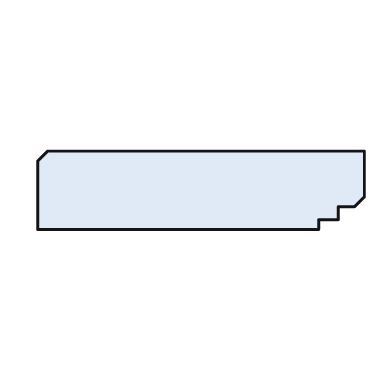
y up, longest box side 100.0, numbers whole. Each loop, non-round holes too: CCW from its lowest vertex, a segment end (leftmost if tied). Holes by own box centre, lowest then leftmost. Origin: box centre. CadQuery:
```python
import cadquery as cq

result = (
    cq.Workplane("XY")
    .moveTo(-50.0, -12.0)
    .lineTo(36.0, -12.0)
    .lineTo(36.0, -9.0)
    .lineTo(42.0, -9.0)
    .lineTo(42.0, -5.0)
    .lineTo(47.0, -5.0)
    .lineTo(50.0, -2.0)
    .lineTo(50.0, 12.0)
    .lineTo(-47.0, 12.0)
    .lineTo(-50.0, 9.0)
    .close()
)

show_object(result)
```